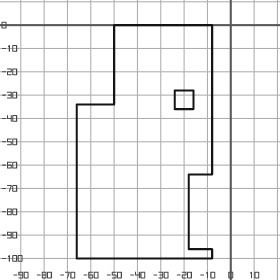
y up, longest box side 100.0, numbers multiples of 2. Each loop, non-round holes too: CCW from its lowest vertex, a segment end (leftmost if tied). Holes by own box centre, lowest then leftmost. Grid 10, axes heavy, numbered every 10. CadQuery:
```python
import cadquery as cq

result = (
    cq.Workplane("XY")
    .moveTo(-66.0, -100.0)
    .lineTo(-8.0, -100.0)
    .lineTo(-8.0, -96.0)
    .lineTo(-18.0, -96.0)
    .lineTo(-18.0, -64.0)
    .lineTo(-8.0, -64.0)
    .lineTo(-8.0, 0.0)
    .lineTo(-50.0, 0.0)
    .lineTo(-50.0, -34.0)
    .lineTo(-66.0, -34.0)
    .close()
    .moveTo(-24.0, -36.0)
    .lineTo(-16.0, -36.0)
    .lineTo(-16.0, -28.0)
    .lineTo(-24.0, -28.0)
    .close()
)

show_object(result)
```